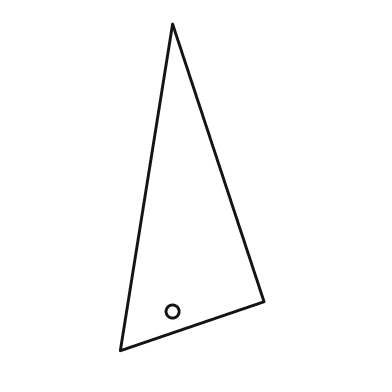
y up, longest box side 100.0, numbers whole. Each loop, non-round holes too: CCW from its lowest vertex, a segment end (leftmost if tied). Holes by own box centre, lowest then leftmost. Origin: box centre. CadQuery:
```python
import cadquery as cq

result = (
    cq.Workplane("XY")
    .moveTo(-22.0, -50.0)
    .lineTo(22.0, -35.0)
    .lineTo(-6.0, 50.0)
    .close()
    .moveTo(-6.0, -38.0)
    .circle(2.0)
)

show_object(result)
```